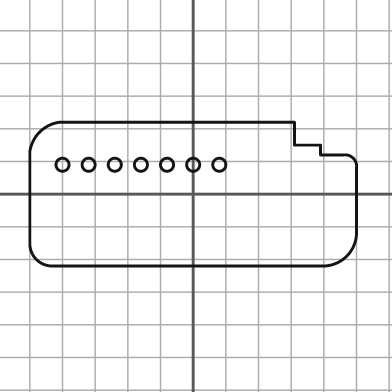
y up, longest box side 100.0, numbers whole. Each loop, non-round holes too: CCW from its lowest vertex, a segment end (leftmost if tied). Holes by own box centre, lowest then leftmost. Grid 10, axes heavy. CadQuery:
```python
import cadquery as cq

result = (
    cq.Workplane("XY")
    .moveTo(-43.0, -22.0)
    .lineTo(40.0, -22.0)
    .threePointArc((47.0, -19.0), (50.0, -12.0))
    .lineTo(50.0, 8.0)
    .threePointArc((49.0, 11.0), (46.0, 12.0))
    .lineTo(39.0, 12.0)
    .lineTo(39.0, 15.0)
    .lineTo(31.0, 15.0)
    .lineTo(31.0, 22.0)
    .lineTo(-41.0, 22.0)
    .threePointArc((-47.0, 19.0), (-50.0, 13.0))
    .lineTo(-50.0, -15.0)
    .threePointArc((-48.0, -20.0), (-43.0, -22.0))
    .close()
    .moveTo(-40.0, 9.0)
    .circle(2.0)
    .moveTo(-32.0, 9.0)
    .circle(2.0)
    .moveTo(-24.0, 9.0)
    .circle(2.0)
    .moveTo(-16.0, 9.0)
    .circle(2.0)
    .moveTo(-8.0, 9.0)
    .circle(2.0)
    .moveTo(0.0, 9.0)
    .circle(2.0)
    .moveTo(8.0, 9.0)
    .circle(2.0)
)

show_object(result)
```